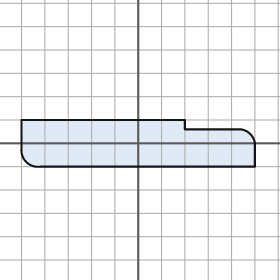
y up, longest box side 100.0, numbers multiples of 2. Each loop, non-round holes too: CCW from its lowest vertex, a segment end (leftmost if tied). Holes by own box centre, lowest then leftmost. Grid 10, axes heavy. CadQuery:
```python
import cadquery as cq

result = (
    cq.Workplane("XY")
    .moveTo(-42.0, -10.0)
    .lineTo(50.0, -10.0)
    .lineTo(50.0, 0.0)
    .threePointArc((48.0, 4.0), (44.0, 6.0))
    .lineTo(20.0, 6.0)
    .lineTo(20.0, 10.0)
    .lineTo(-50.0, 10.0)
    .lineTo(-50.0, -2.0)
    .threePointArc((-48.0, -8.0), (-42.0, -10.0))
    .close()
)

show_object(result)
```